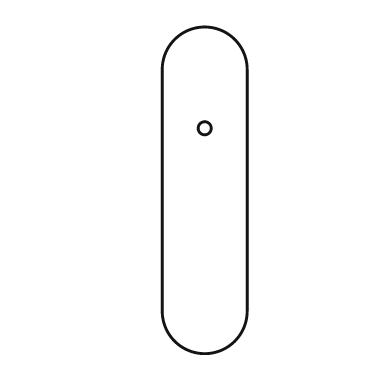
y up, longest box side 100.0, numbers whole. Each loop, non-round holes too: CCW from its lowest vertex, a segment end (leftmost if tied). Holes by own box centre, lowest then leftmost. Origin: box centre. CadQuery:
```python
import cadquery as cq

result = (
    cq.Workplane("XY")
    .moveTo(-13.0, -37.0)
    .threePointArc((0.0, -50.0), (13.0, -37.0))
    .lineTo(13.0, 37.0)
    .threePointArc((0.0, 50.0), (-13.0, 37.0))
    .close()
    .moveTo(0.0, 19.0)
    .circle(2.0)
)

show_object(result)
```